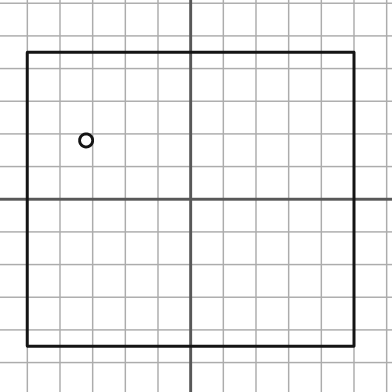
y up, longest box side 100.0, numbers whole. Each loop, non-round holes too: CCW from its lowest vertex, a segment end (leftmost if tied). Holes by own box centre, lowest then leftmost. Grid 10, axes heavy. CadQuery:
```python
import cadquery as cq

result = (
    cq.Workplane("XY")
    .moveTo(-50.0, -45.0)
    .lineTo(50.0, -45.0)
    .lineTo(50.0, 45.0)
    .lineTo(-50.0, 45.0)
    .close()
    .moveTo(-32.0, 18.0)
    .circle(2.0)
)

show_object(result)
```